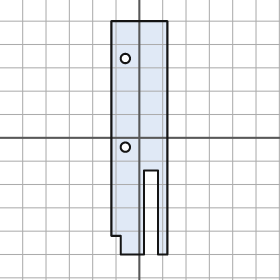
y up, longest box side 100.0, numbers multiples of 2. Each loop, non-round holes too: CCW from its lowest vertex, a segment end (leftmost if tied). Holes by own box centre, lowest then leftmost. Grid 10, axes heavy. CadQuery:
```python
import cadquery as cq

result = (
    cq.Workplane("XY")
    .moveTo(-8.0, -50.0)
    .lineTo(2.0, -50.0)
    .lineTo(2.0, -14.0)
    .lineTo(8.0, -14.0)
    .lineTo(8.0, -50.0)
    .lineTo(12.0, -50.0)
    .lineTo(12.0, 50.0)
    .lineTo(-12.0, 50.0)
    .lineTo(-12.0, -42.0)
    .lineTo(-8.0, -42.0)
    .close()
    .moveTo(-6.0, -4.0)
    .circle(2.0)
    .moveTo(-6.0, 34.0)
    .circle(2.0)
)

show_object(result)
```